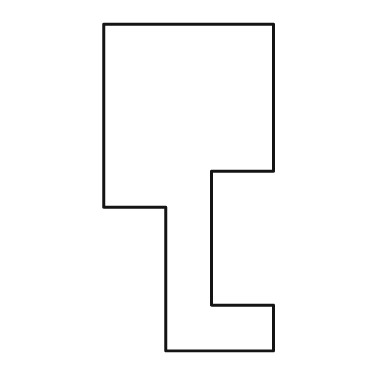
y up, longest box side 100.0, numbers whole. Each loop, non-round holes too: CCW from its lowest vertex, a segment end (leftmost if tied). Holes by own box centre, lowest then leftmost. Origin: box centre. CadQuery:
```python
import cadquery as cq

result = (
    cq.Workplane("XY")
    .moveTo(-7.0, -50.0)
    .lineTo(26.0, -50.0)
    .lineTo(26.0, -36.0)
    .lineTo(7.0, -36.0)
    .lineTo(7.0, 5.0)
    .lineTo(26.0, 5.0)
    .lineTo(26.0, 50.0)
    .lineTo(-26.0, 50.0)
    .lineTo(-26.0, -6.0)
    .lineTo(-7.0, -6.0)
    .close()
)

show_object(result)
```